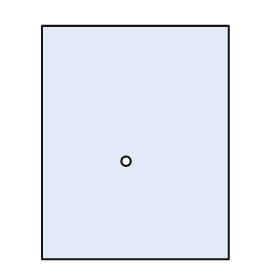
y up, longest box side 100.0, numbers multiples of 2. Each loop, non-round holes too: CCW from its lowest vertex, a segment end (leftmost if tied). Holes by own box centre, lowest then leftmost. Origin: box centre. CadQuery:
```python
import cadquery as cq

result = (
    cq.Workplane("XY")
    .moveTo(-40.0, -50.0)
    .lineTo(40.0, -50.0)
    .lineTo(40.0, 50.0)
    .lineTo(-40.0, 50.0)
    .close()
    .moveTo(-4.0, -8.0)
    .circle(2.0)
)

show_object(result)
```